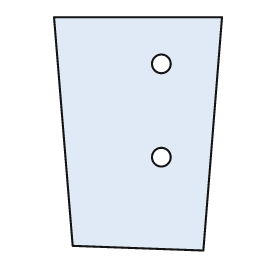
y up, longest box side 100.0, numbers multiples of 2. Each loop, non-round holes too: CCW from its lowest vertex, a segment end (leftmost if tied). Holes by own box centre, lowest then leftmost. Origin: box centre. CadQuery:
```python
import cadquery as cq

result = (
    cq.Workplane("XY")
    .moveTo(28.0, -50.0)
    .lineTo(36.0, 50.0)
    .lineTo(-36.0, 50.0)
    .lineTo(-28.0, -48.0)
    .close()
    .moveTo(10.0, -10.0)
    .circle(4.0)
    .moveTo(10.0, 30.0)
    .circle(4.0)
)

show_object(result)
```